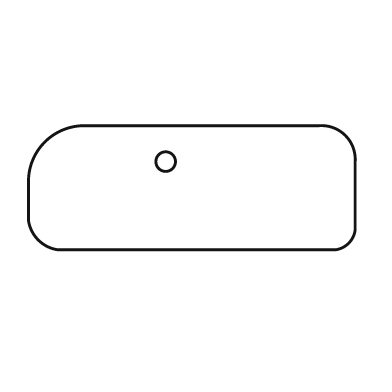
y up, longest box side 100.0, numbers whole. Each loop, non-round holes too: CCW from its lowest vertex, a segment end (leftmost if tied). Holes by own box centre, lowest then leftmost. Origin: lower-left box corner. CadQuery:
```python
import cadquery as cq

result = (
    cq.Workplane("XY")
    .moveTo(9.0, 0.0)
    .lineTo(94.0, 0.0)
    .threePointArc((98.0, 2.0), (100.0, 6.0))
    .lineTo(100.0, 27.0)
    .threePointArc((97.0, 35.0), (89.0, 38.0))
    .lineTo(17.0, 38.0)
    .threePointArc((5.0, 33.0), (0.0, 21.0))
    .lineTo(0.0, 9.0)
    .threePointArc((3.0, 3.0), (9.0, 0.0))
    .close()
    .moveTo(42.0, 27.0)
    .circle(3.0)
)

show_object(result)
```